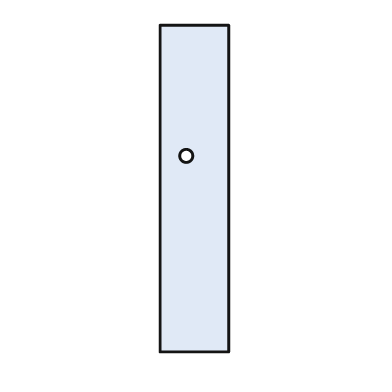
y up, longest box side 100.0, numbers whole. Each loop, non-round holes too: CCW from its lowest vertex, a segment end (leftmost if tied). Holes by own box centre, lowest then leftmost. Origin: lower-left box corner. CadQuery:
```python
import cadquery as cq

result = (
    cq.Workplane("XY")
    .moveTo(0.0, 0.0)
    .lineTo(21.0, 0.0)
    .lineTo(21.0, 100.0)
    .lineTo(0.0, 100.0)
    .close()
    .moveTo(8.0, 60.0)
    .circle(2.0)
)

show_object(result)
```